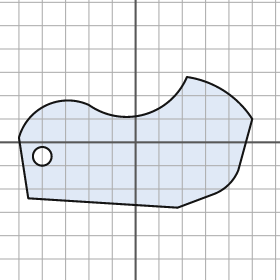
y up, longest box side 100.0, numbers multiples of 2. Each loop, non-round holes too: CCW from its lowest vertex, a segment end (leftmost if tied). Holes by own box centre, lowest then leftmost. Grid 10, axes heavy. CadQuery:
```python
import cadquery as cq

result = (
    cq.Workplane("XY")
    .moveTo(18.0, -28.0)
    .lineTo(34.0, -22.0)
    .threePointArc((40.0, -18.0), (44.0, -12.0))
    .lineTo(50.0, 10.0)
    .threePointArc((38.0, 22.0), (22.0, 28.0))
    .threePointArc((4.0, 12.0), (-20.0, 16.0))
    .threePointArc((-38.0, 16.0), (-50.0, 2.0))
    .lineTo(-46.0, -24.0)
    .close()
    .moveTo(-40.0, -6.0)
    .circle(4.0)
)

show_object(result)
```